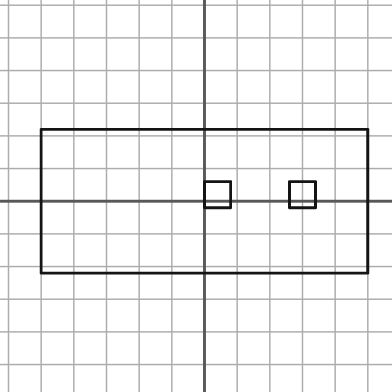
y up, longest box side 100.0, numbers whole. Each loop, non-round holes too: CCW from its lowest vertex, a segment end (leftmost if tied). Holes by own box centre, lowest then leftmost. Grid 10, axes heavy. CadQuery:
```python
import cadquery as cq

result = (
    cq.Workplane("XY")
    .moveTo(-50.0, -22.0)
    .lineTo(50.0, -22.0)
    .lineTo(50.0, 22.0)
    .lineTo(-50.0, 22.0)
    .close()
    .moveTo(0.0, -2.0)
    .lineTo(8.0, -2.0)
    .lineTo(8.0, 6.0)
    .lineTo(0.0, 6.0)
    .close()
    .moveTo(26.0, -2.0)
    .lineTo(34.0, -2.0)
    .lineTo(34.0, 6.0)
    .lineTo(26.0, 6.0)
    .close()
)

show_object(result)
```